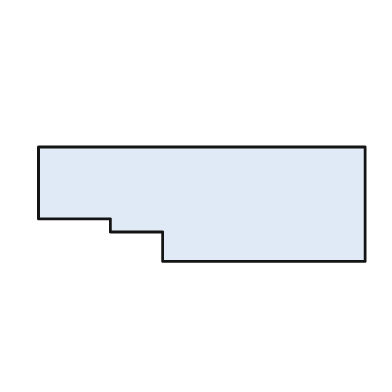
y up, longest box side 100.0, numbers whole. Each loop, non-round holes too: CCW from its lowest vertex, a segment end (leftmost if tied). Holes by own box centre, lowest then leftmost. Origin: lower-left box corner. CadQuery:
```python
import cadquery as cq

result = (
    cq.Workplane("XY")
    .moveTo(38.0, 0.0)
    .lineTo(100.0, 0.0)
    .lineTo(100.0, 35.0)
    .lineTo(0.0, 35.0)
    .lineTo(0.0, 13.0)
    .lineTo(22.0, 13.0)
    .lineTo(22.0, 9.0)
    .lineTo(38.0, 9.0)
    .close()
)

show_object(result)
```